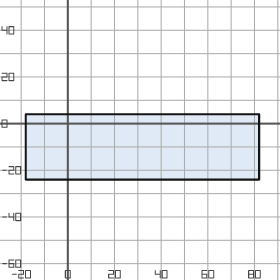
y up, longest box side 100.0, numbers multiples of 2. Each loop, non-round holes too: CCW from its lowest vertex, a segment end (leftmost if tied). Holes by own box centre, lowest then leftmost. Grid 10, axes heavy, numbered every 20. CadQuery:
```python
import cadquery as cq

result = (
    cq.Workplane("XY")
    .moveTo(-18.0, -24.0)
    .lineTo(82.0, -24.0)
    .lineTo(82.0, 4.0)
    .lineTo(-18.0, 4.0)
    .close()
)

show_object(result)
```